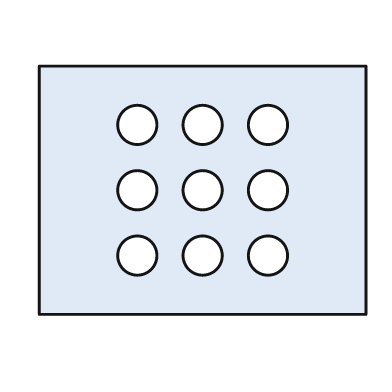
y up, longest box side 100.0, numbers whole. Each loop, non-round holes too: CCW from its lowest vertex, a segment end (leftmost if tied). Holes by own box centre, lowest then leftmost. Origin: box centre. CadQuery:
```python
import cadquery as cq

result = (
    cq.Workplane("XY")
    .moveTo(-50.0, -38.0)
    .lineTo(50.0, -38.0)
    .lineTo(50.0, 38.0)
    .lineTo(-50.0, 38.0)
    .close()
    .moveTo(-20.0, -20.0)
    .circle(6.0)
    .moveTo(0.0, -20.0)
    .circle(6.0)
    .moveTo(20.0, -20.0)
    .circle(6.0)
    .moveTo(-20.0, 0.0)
    .circle(6.0)
    .moveTo(0.0, 0.0)
    .circle(6.0)
    .moveTo(20.0, 0.0)
    .circle(6.0)
    .moveTo(-20.0, 20.0)
    .circle(6.0)
    .moveTo(0.0, 20.0)
    .circle(6.0)
    .moveTo(20.0, 20.0)
    .circle(6.0)
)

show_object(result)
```